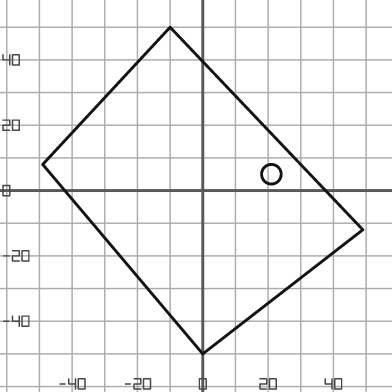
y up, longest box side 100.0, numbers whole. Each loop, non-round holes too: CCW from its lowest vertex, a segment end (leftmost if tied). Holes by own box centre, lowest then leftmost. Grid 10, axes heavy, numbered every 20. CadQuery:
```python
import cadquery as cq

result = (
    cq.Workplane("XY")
    .moveTo(0.0, -50.0)
    .lineTo(49.0, -12.0)
    .lineTo(-10.0, 50.0)
    .lineTo(-49.0, 8.0)
    .close()
    .moveTo(21.0, 5.0)
    .circle(3.0)
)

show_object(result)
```